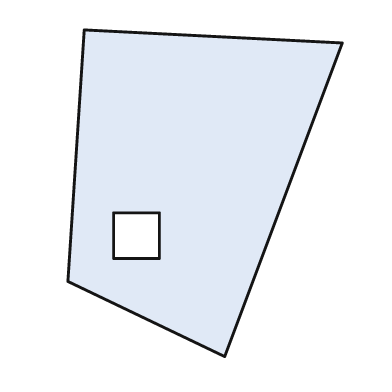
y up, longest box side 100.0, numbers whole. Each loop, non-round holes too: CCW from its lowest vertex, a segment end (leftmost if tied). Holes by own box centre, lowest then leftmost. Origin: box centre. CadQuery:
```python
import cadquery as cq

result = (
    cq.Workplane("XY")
    .moveTo(6.0, -50.0)
    .lineTo(42.0, 46.0)
    .lineTo(-37.0, 50.0)
    .lineTo(-42.0, -27.0)
    .close()
    .moveTo(-28.0, -20.0)
    .lineTo(-14.0, -20.0)
    .lineTo(-14.0, -6.0)
    .lineTo(-28.0, -6.0)
    .close()
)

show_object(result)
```